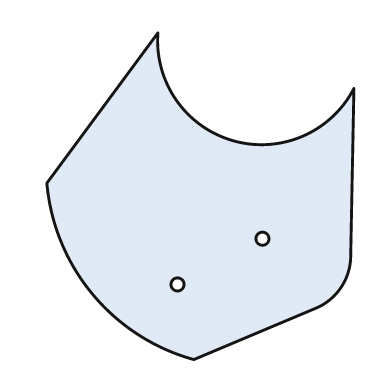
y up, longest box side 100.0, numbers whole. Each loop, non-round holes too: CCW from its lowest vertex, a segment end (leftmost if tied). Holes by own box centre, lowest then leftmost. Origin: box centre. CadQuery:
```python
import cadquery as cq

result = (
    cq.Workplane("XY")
    .moveTo(-2.0, -50.0)
    .lineTo(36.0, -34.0)
    .threePointArc((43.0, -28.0), (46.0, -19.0))
    .lineTo(47.0, 33.0)
    .threePointArc((10.0, 17.0), (-13.0, 50.0))
    .lineTo(-47.0, 4.0)
    .threePointArc((-33.0, -30.0), (-2.0, -50.0))
    .close()
    .moveTo(-7.0, -27.0)
    .circle(2.0)
    .moveTo(19.0, -13.0)
    .circle(2.0)
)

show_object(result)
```